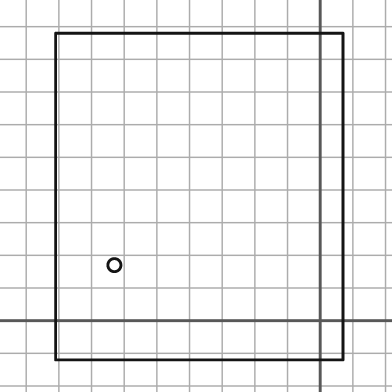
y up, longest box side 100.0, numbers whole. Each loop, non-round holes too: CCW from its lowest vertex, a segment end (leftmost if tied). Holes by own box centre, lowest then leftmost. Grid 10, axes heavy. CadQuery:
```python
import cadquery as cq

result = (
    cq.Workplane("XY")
    .moveTo(-81.0, -12.0)
    .lineTo(7.0, -12.0)
    .lineTo(7.0, 88.0)
    .lineTo(-81.0, 88.0)
    .close()
    .moveTo(-63.0, 17.0)
    .circle(2.0)
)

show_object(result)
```